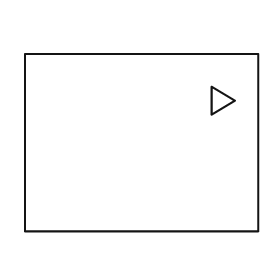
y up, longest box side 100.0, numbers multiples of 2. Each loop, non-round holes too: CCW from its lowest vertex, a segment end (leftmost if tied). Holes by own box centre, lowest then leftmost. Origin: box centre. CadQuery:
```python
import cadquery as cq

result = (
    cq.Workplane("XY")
    .moveTo(-50.0, -38.0)
    .lineTo(50.0, -38.0)
    .lineTo(50.0, 38.0)
    .lineTo(-50.0, 38.0)
    .close()
    .moveTo(30.0, 12.0)
    .lineTo(40.0, 18.0)
    .lineTo(30.0, 24.0)
    .close()
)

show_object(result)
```